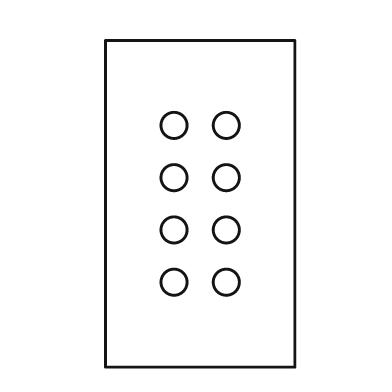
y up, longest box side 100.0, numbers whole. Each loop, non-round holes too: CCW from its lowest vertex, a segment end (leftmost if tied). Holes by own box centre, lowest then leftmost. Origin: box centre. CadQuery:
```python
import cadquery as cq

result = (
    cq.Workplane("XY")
    .moveTo(-29.0, -50.0)
    .lineTo(29.0, -50.0)
    .lineTo(29.0, 50.0)
    .lineTo(-29.0, 50.0)
    .close()
    .moveTo(-8.0, -24.0)
    .circle(4.0)
    .moveTo(8.0, -24.0)
    .circle(4.0)
    .moveTo(-8.0, -8.0)
    .circle(4.0)
    .moveTo(8.0, -8.0)
    .circle(4.0)
    .moveTo(-8.0, 8.0)
    .circle(4.0)
    .moveTo(8.0, 8.0)
    .circle(4.0)
    .moveTo(-8.0, 24.0)
    .circle(4.0)
    .moveTo(8.0, 24.0)
    .circle(4.0)
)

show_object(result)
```